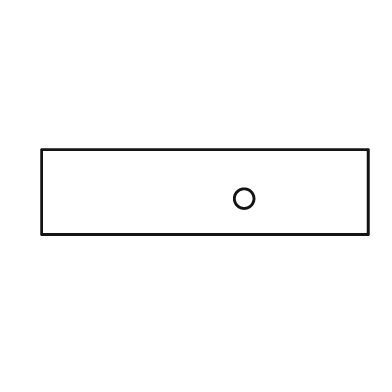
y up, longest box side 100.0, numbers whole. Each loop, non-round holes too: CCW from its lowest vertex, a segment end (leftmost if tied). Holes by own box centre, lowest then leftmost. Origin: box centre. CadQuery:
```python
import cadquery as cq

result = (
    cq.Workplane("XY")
    .moveTo(-50.0, -13.0)
    .lineTo(50.0, -13.0)
    .lineTo(50.0, 13.0)
    .lineTo(-50.0, 13.0)
    .close()
    .moveTo(12.0, -2.0)
    .circle(3.0)
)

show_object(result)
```